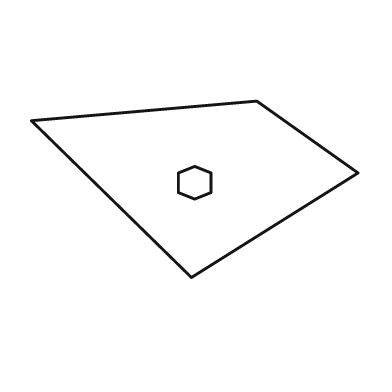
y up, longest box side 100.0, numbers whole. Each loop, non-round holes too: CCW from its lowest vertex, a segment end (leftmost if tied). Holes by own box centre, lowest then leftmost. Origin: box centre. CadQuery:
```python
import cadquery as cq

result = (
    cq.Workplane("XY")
    .moveTo(-1.0, -27.0)
    .lineTo(50.0, 5.0)
    .lineTo(19.0, 27.0)
    .lineTo(-50.0, 21.0)
    .close()
    .moveTo(0.0, -3.0)
    .lineTo(5.0, -1.0)
    .lineTo(5.0, 5.0)
    .lineTo(0.0, 7.0)
    .lineTo(-5.0, 5.0)
    .lineTo(-5.0, -1.0)
    .close()
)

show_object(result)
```